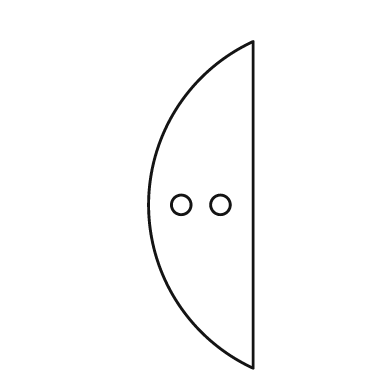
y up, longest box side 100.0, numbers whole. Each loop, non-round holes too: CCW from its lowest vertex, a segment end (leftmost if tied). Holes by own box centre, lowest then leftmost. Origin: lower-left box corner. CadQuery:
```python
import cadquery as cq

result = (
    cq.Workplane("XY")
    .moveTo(32.0, 0.0)
    .lineTo(32.0, 100.0)
    .threePointArc((0.0, 50.0), (32.0, 0.0))
    .close()
    .moveTo(10.0, 50.0)
    .circle(3.0)
    .moveTo(22.0, 50.0)
    .circle(3.0)
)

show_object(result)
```